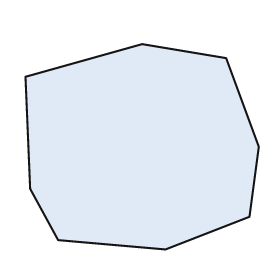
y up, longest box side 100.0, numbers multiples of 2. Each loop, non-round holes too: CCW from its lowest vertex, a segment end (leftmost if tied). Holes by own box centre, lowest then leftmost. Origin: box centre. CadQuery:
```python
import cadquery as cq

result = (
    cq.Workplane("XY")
    .moveTo(10.0, -44.0)
    .lineTo(46.0, -30.0)
    .lineTo(50.0, 0.0)
    .lineTo(36.0, 38.0)
    .lineTo(0.0, 44.0)
    .lineTo(-50.0, 30.0)
    .lineTo(-48.0, -18.0)
    .lineTo(-36.0, -40.0)
    .close()
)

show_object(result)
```